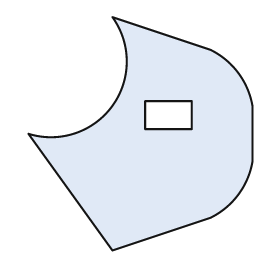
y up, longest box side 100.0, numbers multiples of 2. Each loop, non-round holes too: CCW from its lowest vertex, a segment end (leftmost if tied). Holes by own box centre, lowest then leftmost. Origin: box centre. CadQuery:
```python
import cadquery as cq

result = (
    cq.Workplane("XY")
    .moveTo(-12.0, -50.0)
    .lineTo(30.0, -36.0)
    .threePointArc((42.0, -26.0), (48.0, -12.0))
    .lineTo(48.0, 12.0)
    .threePointArc((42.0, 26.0), (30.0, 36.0))
    .lineTo(-12.0, 50.0)
    .threePointArc((-12.0, 12.0), (-48.0, 0.0))
    .close()
    .moveTo(2.0, 2.0)
    .lineTo(22.0, 2.0)
    .lineTo(22.0, 14.0)
    .lineTo(2.0, 14.0)
    .close()
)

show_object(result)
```